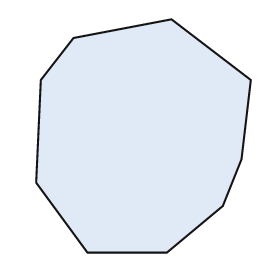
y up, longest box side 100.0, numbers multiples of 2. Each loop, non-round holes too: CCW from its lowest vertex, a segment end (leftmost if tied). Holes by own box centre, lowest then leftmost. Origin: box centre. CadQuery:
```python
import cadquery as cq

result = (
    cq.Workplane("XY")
    .moveTo(-24.0, -50.0)
    .lineTo(10.0, -50.0)
    .lineTo(34.0, -30.0)
    .lineTo(42.0, -10.0)
    .lineTo(46.0, 24.0)
    .lineTo(12.0, 50.0)
    .lineTo(-30.0, 42.0)
    .lineTo(-44.0, 24.0)
    .lineTo(-46.0, -20.0)
    .close()
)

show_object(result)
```